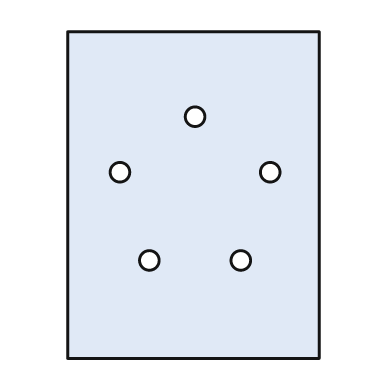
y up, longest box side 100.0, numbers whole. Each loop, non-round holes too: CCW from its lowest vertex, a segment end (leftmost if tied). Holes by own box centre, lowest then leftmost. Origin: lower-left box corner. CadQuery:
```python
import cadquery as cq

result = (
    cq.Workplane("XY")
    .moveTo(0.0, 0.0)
    .lineTo(77.0, 0.0)
    .lineTo(77.0, 100.0)
    .lineTo(0.0, 100.0)
    .close()
    .moveTo(25.0, 30.0)
    .circle(3.0)
    .moveTo(53.0, 30.0)
    .circle(3.0)
    .moveTo(16.0, 57.0)
    .circle(3.0)
    .moveTo(62.0, 57.0)
    .circle(3.0)
    .moveTo(39.0, 74.0)
    .circle(3.0)
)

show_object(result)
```